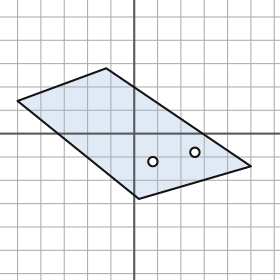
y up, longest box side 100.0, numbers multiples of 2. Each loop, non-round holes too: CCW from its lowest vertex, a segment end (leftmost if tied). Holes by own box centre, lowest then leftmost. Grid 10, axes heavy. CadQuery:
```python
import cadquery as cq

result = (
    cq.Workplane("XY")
    .moveTo(2.0, -28.0)
    .lineTo(50.0, -14.0)
    .lineTo(-12.0, 28.0)
    .lineTo(-50.0, 14.0)
    .close()
    .moveTo(8.0, -12.0)
    .circle(2.0)
    .moveTo(26.0, -8.0)
    .circle(2.0)
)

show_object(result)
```